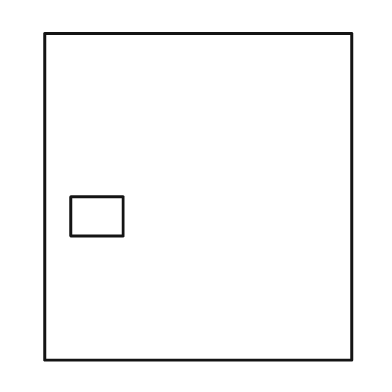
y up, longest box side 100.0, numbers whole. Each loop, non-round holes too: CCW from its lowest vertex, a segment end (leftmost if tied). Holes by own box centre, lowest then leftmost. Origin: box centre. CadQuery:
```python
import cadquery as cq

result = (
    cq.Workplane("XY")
    .moveTo(-47.0, -50.0)
    .lineTo(47.0, -50.0)
    .lineTo(47.0, 50.0)
    .lineTo(-47.0, 50.0)
    .close()
    .moveTo(-39.0, -12.0)
    .lineTo(-23.0, -12.0)
    .lineTo(-23.0, 0.0)
    .lineTo(-39.0, 0.0)
    .close()
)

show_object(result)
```